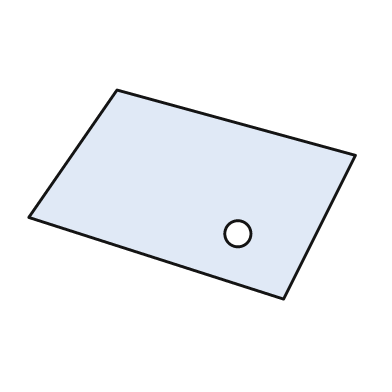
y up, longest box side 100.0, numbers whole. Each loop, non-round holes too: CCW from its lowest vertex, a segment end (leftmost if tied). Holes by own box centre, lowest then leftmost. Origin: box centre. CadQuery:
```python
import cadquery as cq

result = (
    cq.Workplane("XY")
    .moveTo(28.0, -32.0)
    .lineTo(50.0, 12.0)
    .lineTo(-23.0, 32.0)
    .lineTo(-50.0, -7.0)
    .close()
    .moveTo(14.0, -12.0)
    .circle(4.0)
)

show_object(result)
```